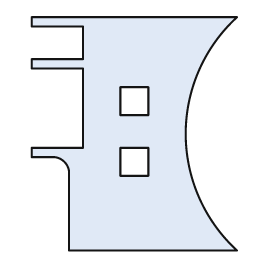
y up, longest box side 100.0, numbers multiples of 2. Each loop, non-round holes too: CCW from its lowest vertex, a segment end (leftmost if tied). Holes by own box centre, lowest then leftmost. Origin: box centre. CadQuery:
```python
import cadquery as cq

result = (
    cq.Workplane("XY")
    .moveTo(-28.0, -50.0)
    .lineTo(44.0, -50.0)
    .threePointArc((22.0, 0.0), (44.0, 50.0))
    .lineTo(-44.0, 50.0)
    .lineTo(-44.0, 46.0)
    .lineTo(-22.0, 46.0)
    .lineTo(-22.0, 32.0)
    .lineTo(-44.0, 32.0)
    .lineTo(-44.0, 28.0)
    .lineTo(-22.0, 28.0)
    .lineTo(-22.0, -6.0)
    .lineTo(-44.0, -6.0)
    .lineTo(-44.0, -10.0)
    .lineTo(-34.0, -10.0)
    .threePointArc((-30.0, -12.0), (-28.0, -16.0))
    .close()
    .moveTo(-6.0, -18.0)
    .lineTo(6.0, -18.0)
    .lineTo(6.0, -6.0)
    .lineTo(-6.0, -6.0)
    .close()
    .moveTo(-6.0, 8.0)
    .lineTo(6.0, 8.0)
    .lineTo(6.0, 20.0)
    .lineTo(-6.0, 20.0)
    .close()
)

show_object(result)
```